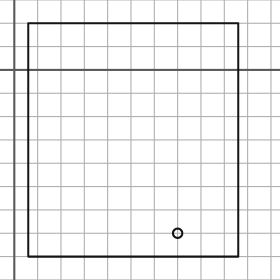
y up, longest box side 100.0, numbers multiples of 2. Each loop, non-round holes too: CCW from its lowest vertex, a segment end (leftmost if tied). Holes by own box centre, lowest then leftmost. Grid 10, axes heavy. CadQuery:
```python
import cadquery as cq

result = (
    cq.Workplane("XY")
    .moveTo(6.0, -80.0)
    .lineTo(96.0, -80.0)
    .lineTo(96.0, 20.0)
    .lineTo(6.0, 20.0)
    .close()
    .moveTo(70.0, -70.0)
    .circle(2.0)
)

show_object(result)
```